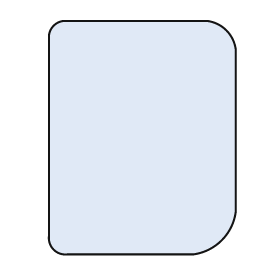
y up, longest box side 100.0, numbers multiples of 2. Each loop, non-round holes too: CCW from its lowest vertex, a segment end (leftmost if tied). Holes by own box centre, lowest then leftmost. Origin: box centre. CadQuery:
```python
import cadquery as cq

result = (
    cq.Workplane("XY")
    .moveTo(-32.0, -50.0)
    .lineTo(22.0, -50.0)
    .threePointArc((34.0, -44.0), (40.0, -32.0))
    .lineTo(40.0, 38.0)
    .threePointArc((36.0, 46.0), (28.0, 50.0))
    .lineTo(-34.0, 50.0)
    .threePointArc((-38.0, 48.0), (-40.0, 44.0))
    .lineTo(-40.0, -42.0)
    .threePointArc((-38.0, -48.0), (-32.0, -50.0))
    .close()
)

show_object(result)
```